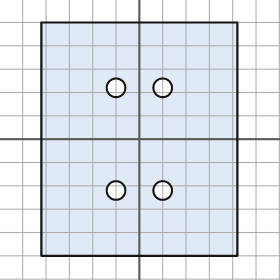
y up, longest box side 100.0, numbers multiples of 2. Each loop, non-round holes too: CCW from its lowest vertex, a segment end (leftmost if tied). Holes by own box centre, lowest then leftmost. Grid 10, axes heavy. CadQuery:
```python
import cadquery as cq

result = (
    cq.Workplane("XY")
    .moveTo(-42.0, -50.0)
    .lineTo(42.0, -50.0)
    .lineTo(42.0, 50.0)
    .lineTo(-42.0, 50.0)
    .close()
    .moveTo(-10.0, -22.0)
    .circle(4.0)
    .moveTo(10.0, -22.0)
    .circle(4.0)
    .moveTo(-10.0, 22.0)
    .circle(4.0)
    .moveTo(10.0, 22.0)
    .circle(4.0)
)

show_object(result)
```